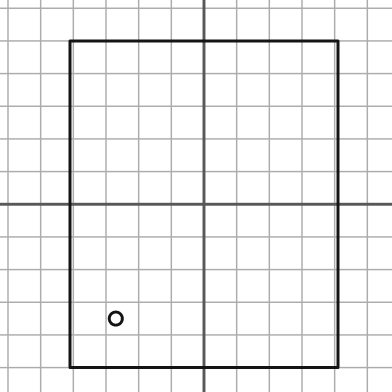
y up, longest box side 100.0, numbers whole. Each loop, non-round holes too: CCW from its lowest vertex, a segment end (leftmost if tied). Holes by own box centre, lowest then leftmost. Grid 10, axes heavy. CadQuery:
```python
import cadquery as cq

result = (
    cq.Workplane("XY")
    .moveTo(-41.0, -50.0)
    .lineTo(41.0, -50.0)
    .lineTo(41.0, 50.0)
    .lineTo(-41.0, 50.0)
    .close()
    .moveTo(-27.0, -35.0)
    .circle(2.0)
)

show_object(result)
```